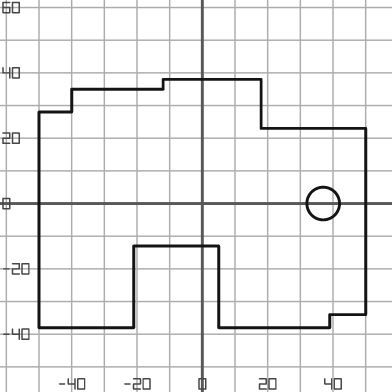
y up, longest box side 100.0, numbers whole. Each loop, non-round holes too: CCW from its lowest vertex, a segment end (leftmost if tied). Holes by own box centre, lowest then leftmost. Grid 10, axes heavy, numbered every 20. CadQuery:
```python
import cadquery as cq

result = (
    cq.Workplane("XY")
    .moveTo(-50.0, -38.0)
    .lineTo(-21.0, -38.0)
    .lineTo(-21.0, -13.0)
    .lineTo(5.0, -13.0)
    .lineTo(5.0, -38.0)
    .lineTo(39.0, -38.0)
    .lineTo(39.0, -34.0)
    .lineTo(50.0, -34.0)
    .lineTo(50.0, 23.0)
    .lineTo(18.0, 23.0)
    .lineTo(18.0, 38.0)
    .lineTo(-12.0, 38.0)
    .lineTo(-12.0, 35.0)
    .lineTo(-40.0, 35.0)
    .lineTo(-40.0, 28.0)
    .lineTo(-50.0, 28.0)
    .close()
    .moveTo(37.0, 0.0)
    .circle(5.0)
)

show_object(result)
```